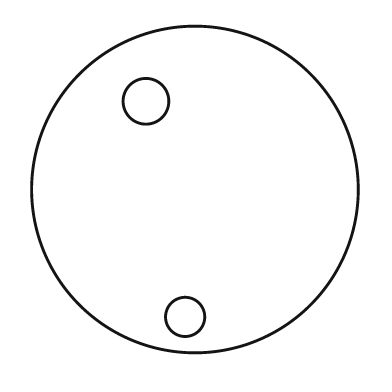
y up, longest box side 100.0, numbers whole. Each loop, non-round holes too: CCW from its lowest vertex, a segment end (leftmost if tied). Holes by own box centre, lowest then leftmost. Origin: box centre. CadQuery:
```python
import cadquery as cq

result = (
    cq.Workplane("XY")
    .moveTo(0.0, 0.0)
    .circle(50.0)
    .moveTo(-3.0, -39.0)
    .circle(6.0)
    .moveTo(-15.0, 27.0)
    .circle(7.0)
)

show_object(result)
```